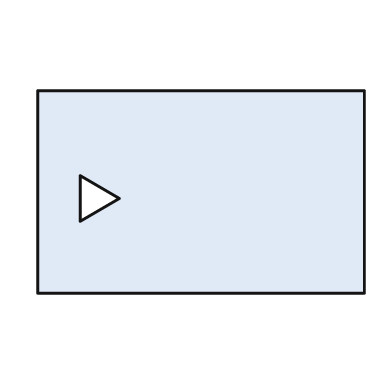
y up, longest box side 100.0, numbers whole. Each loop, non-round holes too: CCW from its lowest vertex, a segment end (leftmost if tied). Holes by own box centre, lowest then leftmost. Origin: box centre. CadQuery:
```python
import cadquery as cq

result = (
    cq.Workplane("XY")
    .moveTo(-50.0, -31.0)
    .lineTo(50.0, -31.0)
    .lineTo(50.0, 31.0)
    .lineTo(-50.0, 31.0)
    .close()
    .moveTo(-37.0, -9.0)
    .lineTo(-25.0, -2.0)
    .lineTo(-37.0, 5.0)
    .close()
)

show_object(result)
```